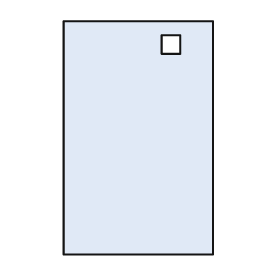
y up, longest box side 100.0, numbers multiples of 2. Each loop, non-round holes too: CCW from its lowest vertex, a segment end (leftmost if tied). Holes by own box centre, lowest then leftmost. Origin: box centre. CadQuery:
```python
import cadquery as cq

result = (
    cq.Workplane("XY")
    .moveTo(-32.0, -50.0)
    .lineTo(32.0, -50.0)
    .lineTo(32.0, 50.0)
    .lineTo(-32.0, 50.0)
    .close()
    .moveTo(10.0, 36.0)
    .lineTo(18.0, 36.0)
    .lineTo(18.0, 44.0)
    .lineTo(10.0, 44.0)
    .close()
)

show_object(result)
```